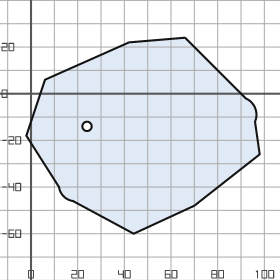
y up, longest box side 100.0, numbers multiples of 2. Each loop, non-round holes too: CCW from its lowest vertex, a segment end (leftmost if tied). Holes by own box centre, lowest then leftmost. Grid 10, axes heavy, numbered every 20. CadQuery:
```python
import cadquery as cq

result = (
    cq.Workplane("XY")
    .moveTo(44.0, -60.0)
    .lineTo(70.0, -48.0)
    .lineTo(98.0, -26.0)
    .lineTo(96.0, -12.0)
    .threePointArc((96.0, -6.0), (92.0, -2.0))
    .lineTo(66.0, 24.0)
    .lineTo(42.0, 22.0)
    .lineTo(6.0, 6.0)
    .lineTo(-2.0, -18.0)
    .lineTo(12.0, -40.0)
    .threePointArc((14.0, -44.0), (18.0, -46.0))
    .close()
    .moveTo(24.0, -14.0)
    .circle(2.0)
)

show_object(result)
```